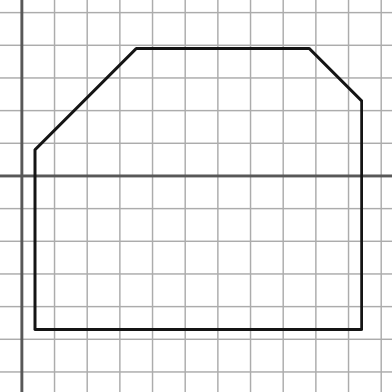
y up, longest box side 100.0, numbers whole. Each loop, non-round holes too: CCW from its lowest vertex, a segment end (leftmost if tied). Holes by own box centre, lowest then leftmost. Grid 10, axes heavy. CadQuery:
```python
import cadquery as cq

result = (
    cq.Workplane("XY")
    .moveTo(4.0, -47.0)
    .lineTo(104.0, -47.0)
    .lineTo(104.0, 23.0)
    .lineTo(88.0, 39.0)
    .lineTo(35.0, 39.0)
    .lineTo(4.0, 8.0)
    .close()
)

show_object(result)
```